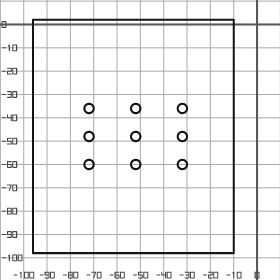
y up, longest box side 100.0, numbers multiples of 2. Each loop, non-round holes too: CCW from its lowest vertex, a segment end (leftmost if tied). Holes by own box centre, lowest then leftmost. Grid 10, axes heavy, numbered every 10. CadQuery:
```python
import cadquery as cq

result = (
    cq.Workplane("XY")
    .moveTo(-96.0, -98.0)
    .lineTo(-10.0, -98.0)
    .lineTo(-10.0, 2.0)
    .lineTo(-96.0, 2.0)
    .close()
    .moveTo(-72.0, -60.0)
    .circle(2.0)
    .moveTo(-52.0, -60.0)
    .circle(2.0)
    .moveTo(-32.0, -60.0)
    .circle(2.0)
    .moveTo(-72.0, -48.0)
    .circle(2.0)
    .moveTo(-52.0, -48.0)
    .circle(2.0)
    .moveTo(-32.0, -48.0)
    .circle(2.0)
    .moveTo(-72.0, -36.0)
    .circle(2.0)
    .moveTo(-52.0, -36.0)
    .circle(2.0)
    .moveTo(-32.0, -36.0)
    .circle(2.0)
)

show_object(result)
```